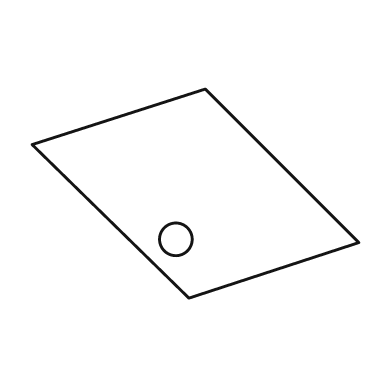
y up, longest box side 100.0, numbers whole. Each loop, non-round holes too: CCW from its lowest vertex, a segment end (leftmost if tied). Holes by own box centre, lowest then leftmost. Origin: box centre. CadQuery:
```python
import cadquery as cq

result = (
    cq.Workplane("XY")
    .moveTo(-2.0, -32.0)
    .lineTo(50.0, -15.0)
    .lineTo(3.0, 32.0)
    .lineTo(-50.0, 15.0)
    .close()
    .moveTo(-6.0, -14.0)
    .circle(5.0)
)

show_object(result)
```